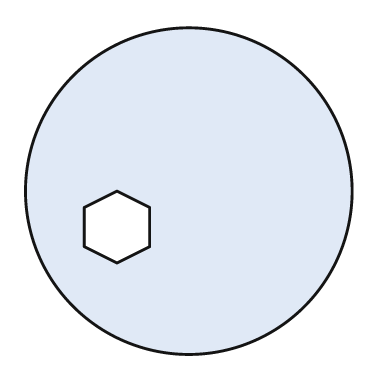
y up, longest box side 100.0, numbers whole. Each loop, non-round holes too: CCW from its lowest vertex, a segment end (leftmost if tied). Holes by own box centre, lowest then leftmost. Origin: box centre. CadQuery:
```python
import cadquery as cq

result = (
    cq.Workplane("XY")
    .moveTo(0.0, 0.0)
    .circle(50.0)
    .moveTo(-22.0, -22.0)
    .lineTo(-12.0, -17.0)
    .lineTo(-12.0, -5.0)
    .lineTo(-22.0, 0.0)
    .lineTo(-32.0, -5.0)
    .lineTo(-32.0, -17.0)
    .close()
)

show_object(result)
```